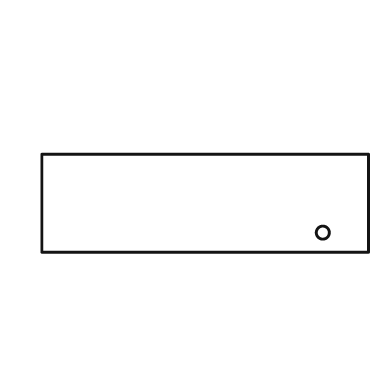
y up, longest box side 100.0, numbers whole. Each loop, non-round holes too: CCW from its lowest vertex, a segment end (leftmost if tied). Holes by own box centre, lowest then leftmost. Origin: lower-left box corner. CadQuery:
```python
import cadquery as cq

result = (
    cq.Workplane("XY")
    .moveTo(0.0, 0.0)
    .lineTo(100.0, 0.0)
    .lineTo(100.0, 30.0)
    .lineTo(0.0, 30.0)
    .close()
    .moveTo(86.0, 6.0)
    .circle(2.0)
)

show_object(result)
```